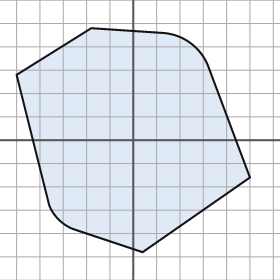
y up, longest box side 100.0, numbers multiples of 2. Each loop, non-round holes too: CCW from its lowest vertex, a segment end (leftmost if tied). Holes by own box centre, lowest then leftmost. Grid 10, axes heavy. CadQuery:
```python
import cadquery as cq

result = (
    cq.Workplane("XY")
    .moveTo(4.0, -48.0)
    .lineTo(50.0, -16.0)
    .lineTo(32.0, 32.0)
    .threePointArc((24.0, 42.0), (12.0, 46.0))
    .lineTo(-18.0, 48.0)
    .lineTo(-50.0, 28.0)
    .lineTo(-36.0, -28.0)
    .threePointArc((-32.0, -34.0), (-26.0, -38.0))
    .close()
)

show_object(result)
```